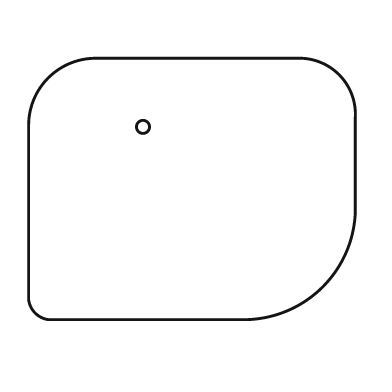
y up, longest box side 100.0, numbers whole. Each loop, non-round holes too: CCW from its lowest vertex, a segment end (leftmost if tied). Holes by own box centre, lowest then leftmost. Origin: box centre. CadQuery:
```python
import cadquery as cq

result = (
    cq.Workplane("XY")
    .moveTo(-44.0, -40.0)
    .lineTo(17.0, -40.0)
    .threePointArc((40.0, -30.0), (50.0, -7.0))
    .lineTo(50.0, 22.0)
    .threePointArc((45.0, 35.0), (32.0, 40.0))
    .lineTo(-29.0, 40.0)
    .threePointArc((-44.0, 34.0), (-50.0, 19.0))
    .lineTo(-50.0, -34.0)
    .threePointArc((-48.0, -38.0), (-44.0, -40.0))
    .close()
    .moveTo(-15.0, 19.0)
    .circle(2.0)
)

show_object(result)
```